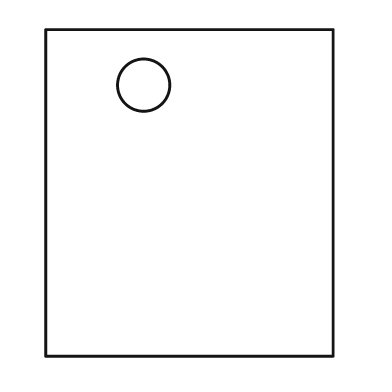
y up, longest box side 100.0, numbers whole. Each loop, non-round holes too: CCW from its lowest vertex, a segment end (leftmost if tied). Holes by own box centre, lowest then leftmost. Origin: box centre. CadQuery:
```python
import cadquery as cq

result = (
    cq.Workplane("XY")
    .moveTo(-44.0, -50.0)
    .lineTo(44.0, -50.0)
    .lineTo(44.0, 50.0)
    .lineTo(-44.0, 50.0)
    .close()
    .moveTo(-14.0, 33.0)
    .circle(8.0)
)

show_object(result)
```